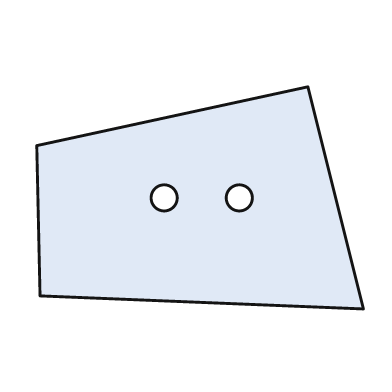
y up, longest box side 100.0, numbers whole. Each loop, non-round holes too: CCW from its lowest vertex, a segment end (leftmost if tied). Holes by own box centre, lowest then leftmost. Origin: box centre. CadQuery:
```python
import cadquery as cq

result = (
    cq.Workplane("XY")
    .moveTo(50.0, -34.0)
    .lineTo(33.0, 34.0)
    .lineTo(-50.0, 16.0)
    .lineTo(-49.0, -30.0)
    .close()
    .moveTo(-11.0, 0.0)
    .circle(4.0)
    .moveTo(12.0, 0.0)
    .circle(4.0)
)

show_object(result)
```